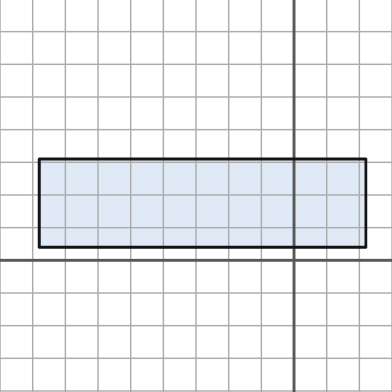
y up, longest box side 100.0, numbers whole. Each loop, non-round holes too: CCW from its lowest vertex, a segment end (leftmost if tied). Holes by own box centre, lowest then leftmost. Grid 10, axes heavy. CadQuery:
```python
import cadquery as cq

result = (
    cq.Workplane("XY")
    .moveTo(-78.0, 4.0)
    .lineTo(22.0, 4.0)
    .lineTo(22.0, 31.0)
    .lineTo(-78.0, 31.0)
    .close()
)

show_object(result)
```